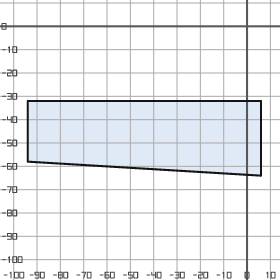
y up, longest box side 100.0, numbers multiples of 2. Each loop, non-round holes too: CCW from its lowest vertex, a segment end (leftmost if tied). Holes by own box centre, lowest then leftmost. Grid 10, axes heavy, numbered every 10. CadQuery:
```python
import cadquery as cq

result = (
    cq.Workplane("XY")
    .moveTo(6.0, -64.0)
    .lineTo(6.0, -32.0)
    .lineTo(-94.0, -32.0)
    .lineTo(-94.0, -58.0)
    .close()
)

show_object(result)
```